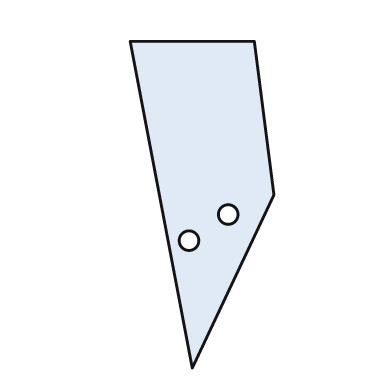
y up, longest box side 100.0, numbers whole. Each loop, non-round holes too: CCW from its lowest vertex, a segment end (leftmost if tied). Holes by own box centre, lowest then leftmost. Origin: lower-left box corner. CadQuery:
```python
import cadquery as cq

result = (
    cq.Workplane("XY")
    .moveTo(19.0, 0.0)
    .lineTo(44.0, 53.0)
    .lineTo(38.0, 100.0)
    .lineTo(0.0, 100.0)
    .close()
    .moveTo(18.0, 39.0)
    .circle(3.0)
    .moveTo(30.0, 47.0)
    .circle(3.0)
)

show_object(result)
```